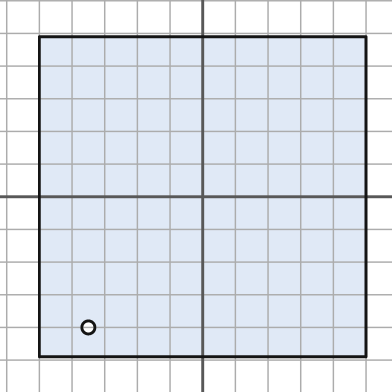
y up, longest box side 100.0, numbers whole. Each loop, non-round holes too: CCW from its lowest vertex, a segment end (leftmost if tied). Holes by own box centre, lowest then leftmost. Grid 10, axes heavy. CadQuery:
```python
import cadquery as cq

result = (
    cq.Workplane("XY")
    .moveTo(-50.0, -49.0)
    .lineTo(50.0, -49.0)
    .lineTo(50.0, 49.0)
    .lineTo(-50.0, 49.0)
    .close()
    .moveTo(-35.0, -40.0)
    .circle(2.0)
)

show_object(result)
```